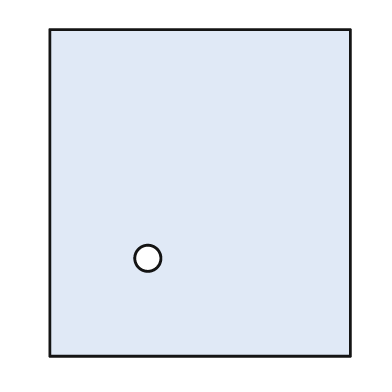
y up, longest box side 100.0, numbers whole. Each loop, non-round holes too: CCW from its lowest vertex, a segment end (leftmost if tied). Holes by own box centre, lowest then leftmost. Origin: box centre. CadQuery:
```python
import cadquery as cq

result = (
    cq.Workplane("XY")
    .moveTo(-46.0, -50.0)
    .lineTo(46.0, -50.0)
    .lineTo(46.0, 50.0)
    .lineTo(-46.0, 50.0)
    .close()
    .moveTo(-16.0, -20.0)
    .circle(4.0)
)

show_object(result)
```